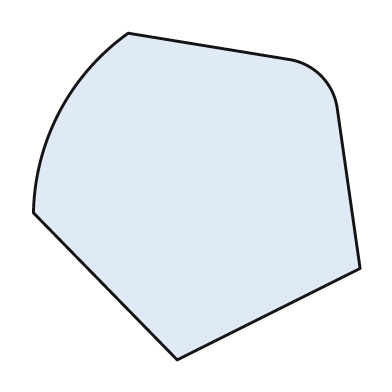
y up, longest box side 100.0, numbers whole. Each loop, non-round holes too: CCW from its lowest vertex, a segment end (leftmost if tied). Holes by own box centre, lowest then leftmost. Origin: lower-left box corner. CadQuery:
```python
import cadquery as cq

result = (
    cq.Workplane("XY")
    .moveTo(44.0, 0.0)
    .lineTo(100.0, 28.0)
    .lineTo(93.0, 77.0)
    .threePointArc((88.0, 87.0), (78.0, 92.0))
    .lineTo(29.0, 100.0)
    .threePointArc((8.0, 76.0), (0.0, 45.0))
    .close()
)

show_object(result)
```